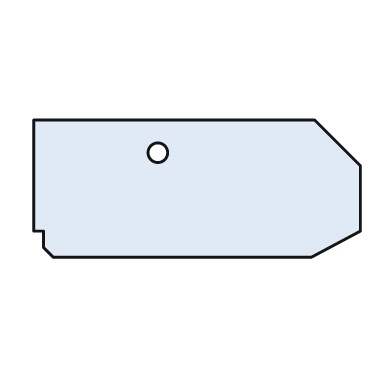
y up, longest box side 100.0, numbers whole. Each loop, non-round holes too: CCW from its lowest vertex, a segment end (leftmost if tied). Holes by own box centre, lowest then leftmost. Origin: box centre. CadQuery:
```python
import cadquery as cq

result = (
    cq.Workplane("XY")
    .moveTo(-44.0, -21.0)
    .lineTo(35.0, -21.0)
    .lineTo(50.0, -13.0)
    .lineTo(50.0, 7.0)
    .lineTo(36.0, 21.0)
    .lineTo(-50.0, 21.0)
    .lineTo(-50.0, -13.0)
    .lineTo(-47.0, -13.0)
    .lineTo(-47.0, -18.0)
    .close()
    .moveTo(-12.0, 11.0)
    .circle(3.0)
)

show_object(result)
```